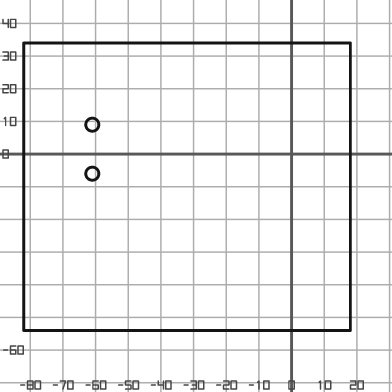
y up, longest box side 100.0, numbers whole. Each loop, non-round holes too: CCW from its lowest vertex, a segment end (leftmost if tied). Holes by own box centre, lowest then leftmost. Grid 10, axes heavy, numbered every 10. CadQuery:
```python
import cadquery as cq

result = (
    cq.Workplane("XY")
    .moveTo(-82.0, -54.0)
    .lineTo(18.0, -54.0)
    .lineTo(18.0, 34.0)
    .lineTo(-82.0, 34.0)
    .close()
    .moveTo(-61.0, -6.0)
    .circle(2.0)
    .moveTo(-61.0, 9.0)
    .circle(2.0)
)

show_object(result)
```